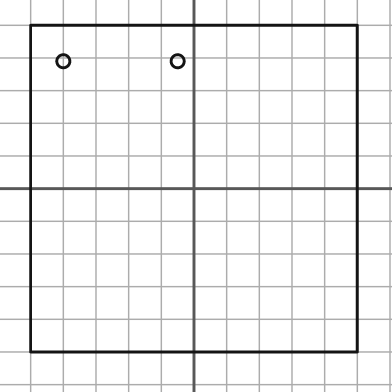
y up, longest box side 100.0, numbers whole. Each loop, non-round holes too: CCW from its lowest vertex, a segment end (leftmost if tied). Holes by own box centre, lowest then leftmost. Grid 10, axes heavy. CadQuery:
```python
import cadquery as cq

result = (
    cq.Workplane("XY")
    .moveTo(-50.0, -50.0)
    .lineTo(50.0, -50.0)
    .lineTo(50.0, 50.0)
    .lineTo(-50.0, 50.0)
    .close()
    .moveTo(-40.0, 39.0)
    .circle(2.0)
    .moveTo(-5.0, 39.0)
    .circle(2.0)
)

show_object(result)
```